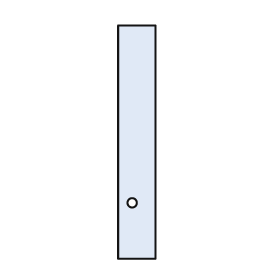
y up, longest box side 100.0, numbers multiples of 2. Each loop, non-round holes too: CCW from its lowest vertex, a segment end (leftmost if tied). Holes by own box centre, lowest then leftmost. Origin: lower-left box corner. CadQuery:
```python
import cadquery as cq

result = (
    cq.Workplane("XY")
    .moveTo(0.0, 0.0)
    .lineTo(16.0, 0.0)
    .lineTo(16.0, 100.0)
    .lineTo(0.0, 100.0)
    .close()
    .moveTo(6.0, 24.0)
    .circle(2.0)
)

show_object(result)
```